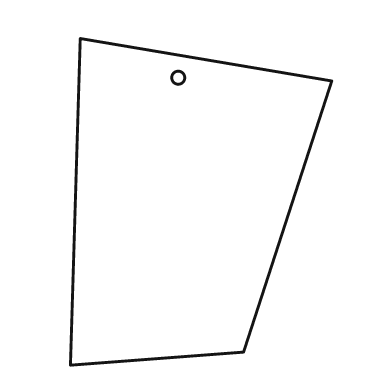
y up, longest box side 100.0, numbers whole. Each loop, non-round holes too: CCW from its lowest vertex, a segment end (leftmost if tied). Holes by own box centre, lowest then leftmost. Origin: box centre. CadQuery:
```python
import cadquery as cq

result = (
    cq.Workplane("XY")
    .moveTo(-40.0, -50.0)
    .lineTo(13.0, -46.0)
    .lineTo(40.0, 37.0)
    .lineTo(-37.0, 50.0)
    .close()
    .moveTo(-7.0, 38.0)
    .circle(2.0)
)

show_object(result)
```